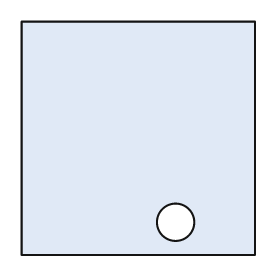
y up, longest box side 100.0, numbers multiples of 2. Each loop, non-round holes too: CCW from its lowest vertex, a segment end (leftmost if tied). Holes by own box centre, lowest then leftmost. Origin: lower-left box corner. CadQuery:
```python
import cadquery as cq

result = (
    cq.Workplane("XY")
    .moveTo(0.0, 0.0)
    .lineTo(100.0, 0.0)
    .lineTo(100.0, 100.0)
    .lineTo(0.0, 100.0)
    .close()
    .moveTo(66.0, 14.0)
    .circle(8.0)
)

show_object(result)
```